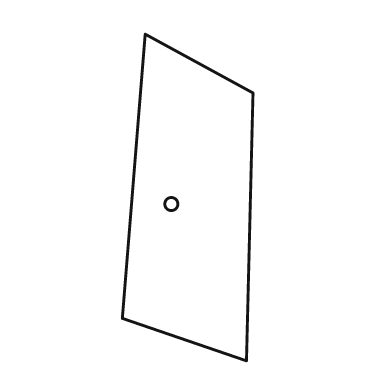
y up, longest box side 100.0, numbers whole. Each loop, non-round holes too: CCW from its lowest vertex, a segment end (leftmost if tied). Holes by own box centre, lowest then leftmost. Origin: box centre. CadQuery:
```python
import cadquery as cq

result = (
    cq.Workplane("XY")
    .moveTo(18.0, -50.0)
    .lineTo(20.0, 32.0)
    .lineTo(-13.0, 50.0)
    .lineTo(-20.0, -37.0)
    .close()
    .moveTo(-5.0, -2.0)
    .circle(2.0)
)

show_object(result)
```